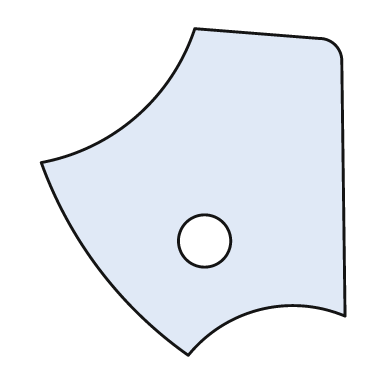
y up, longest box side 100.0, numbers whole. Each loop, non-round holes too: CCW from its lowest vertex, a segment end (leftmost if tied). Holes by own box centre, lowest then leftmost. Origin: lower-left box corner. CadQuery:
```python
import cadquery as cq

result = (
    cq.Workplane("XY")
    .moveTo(45.0, 0.0)
    .threePointArc((67.0, 14.0), (93.0, 12.0))
    .lineTo(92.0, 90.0)
    .threePointArc((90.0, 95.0), (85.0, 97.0))
    .lineTo(47.0, 100.0)
    .threePointArc((29.0, 73.0), (0.0, 59.0))
    .threePointArc((18.0, 26.0), (45.0, 0.0))
    .close()
    .moveTo(50.0, 35.0)
    .circle(8.0)
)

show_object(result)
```